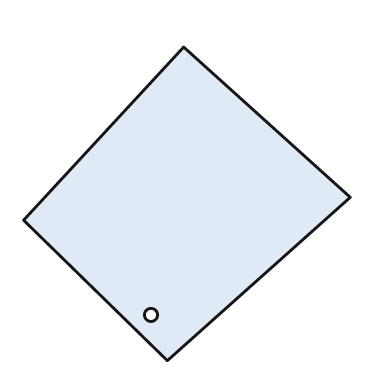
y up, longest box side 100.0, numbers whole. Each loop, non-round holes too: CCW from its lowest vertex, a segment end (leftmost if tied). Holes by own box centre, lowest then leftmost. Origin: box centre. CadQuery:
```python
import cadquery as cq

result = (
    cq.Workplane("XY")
    .moveTo(-6.0, -48.0)
    .lineTo(50.0, 2.0)
    .lineTo(-1.0, 48.0)
    .lineTo(-50.0, -5.0)
    .close()
    .moveTo(-11.0, -34.0)
    .circle(2.0)
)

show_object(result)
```